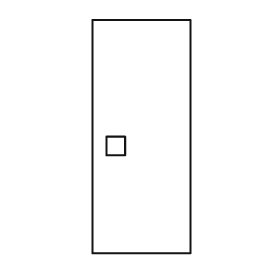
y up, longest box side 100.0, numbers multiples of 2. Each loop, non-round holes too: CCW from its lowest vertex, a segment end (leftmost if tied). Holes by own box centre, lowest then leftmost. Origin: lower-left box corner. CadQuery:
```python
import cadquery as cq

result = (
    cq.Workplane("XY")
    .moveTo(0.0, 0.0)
    .lineTo(42.0, 0.0)
    .lineTo(42.0, 100.0)
    .lineTo(0.0, 100.0)
    .close()
    .moveTo(6.0, 42.0)
    .lineTo(14.0, 42.0)
    .lineTo(14.0, 50.0)
    .lineTo(6.0, 50.0)
    .close()
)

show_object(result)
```